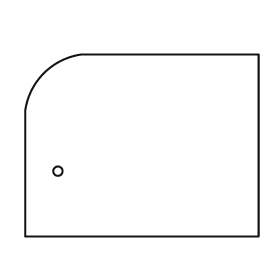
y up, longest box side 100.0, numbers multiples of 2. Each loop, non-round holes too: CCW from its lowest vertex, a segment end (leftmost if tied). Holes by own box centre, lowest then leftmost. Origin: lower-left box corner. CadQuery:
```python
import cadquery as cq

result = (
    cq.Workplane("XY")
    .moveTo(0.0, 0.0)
    .lineTo(100.0, 0.0)
    .lineTo(100.0, 78.0)
    .lineTo(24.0, 78.0)
    .threePointArc((8.0, 70.0), (0.0, 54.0))
    .close()
    .moveTo(14.0, 28.0)
    .circle(2.0)
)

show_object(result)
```